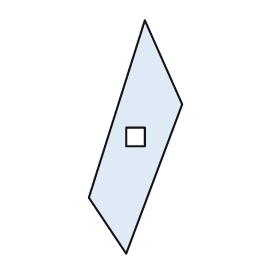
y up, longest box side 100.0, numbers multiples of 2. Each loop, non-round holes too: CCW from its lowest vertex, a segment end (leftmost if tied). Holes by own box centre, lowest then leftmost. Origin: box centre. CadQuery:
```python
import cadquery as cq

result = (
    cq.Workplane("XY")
    .moveTo(-4.0, -50.0)
    .lineTo(20.0, 14.0)
    .lineTo(4.0, 50.0)
    .lineTo(-20.0, -26.0)
    .close()
    .moveTo(-4.0, -4.0)
    .lineTo(4.0, -4.0)
    .lineTo(4.0, 4.0)
    .lineTo(-4.0, 4.0)
    .close()
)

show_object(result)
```